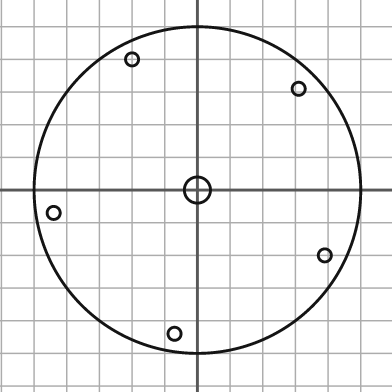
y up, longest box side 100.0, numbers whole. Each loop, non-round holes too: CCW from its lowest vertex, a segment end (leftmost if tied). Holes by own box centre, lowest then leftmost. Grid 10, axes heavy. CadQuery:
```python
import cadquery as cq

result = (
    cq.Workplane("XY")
    .moveTo(0.0, 0.0)
    .circle(50.0)
    .moveTo(-7.0, -44.0)
    .circle(2.0)
    .moveTo(39.0, -20.0)
    .circle(2.0)
    .moveTo(-44.0, -7.0)
    .circle(2.0)
    .moveTo(0.0, 0.0)
    .circle(4.0)
    .moveTo(31.0, 31.0)
    .circle(2.0)
    .moveTo(-20.0, 40.0)
    .circle(2.0)
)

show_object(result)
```